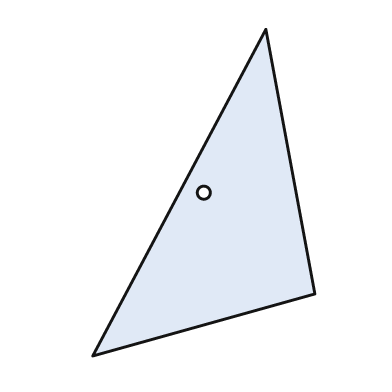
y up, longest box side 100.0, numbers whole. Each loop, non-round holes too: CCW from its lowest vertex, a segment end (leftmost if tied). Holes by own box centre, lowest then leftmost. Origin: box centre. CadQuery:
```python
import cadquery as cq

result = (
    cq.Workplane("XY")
    .moveTo(-34.0, -50.0)
    .lineTo(34.0, -31.0)
    .lineTo(19.0, 50.0)
    .close()
    .moveTo(0.0, 0.0)
    .circle(2.0)
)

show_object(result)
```